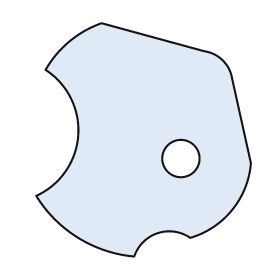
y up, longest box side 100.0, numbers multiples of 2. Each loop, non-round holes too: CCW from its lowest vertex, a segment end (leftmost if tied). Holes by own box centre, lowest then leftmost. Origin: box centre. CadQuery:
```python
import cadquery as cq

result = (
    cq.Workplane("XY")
    .moveTo(-4.0, -50.0)
    .threePointArc((6.0, -40.0), (20.0, -42.0))
    .threePointArc((38.0, -30.0), (46.0, -10.0))
    .lineTo(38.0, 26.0)
    .threePointArc((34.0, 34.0), (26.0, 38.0))
    .lineTo(-18.0, 50.0)
    .threePointArc((-32.0, 42.0), (-42.0, 30.0))
    .threePointArc((-28.0, 2.0), (-46.0, -24.0))
    .threePointArc((-28.0, -42.0), (-4.0, -50.0))
    .close()
    .moveTo(16.0, -8.0)
    .circle(8.0)
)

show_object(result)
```